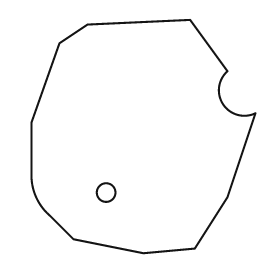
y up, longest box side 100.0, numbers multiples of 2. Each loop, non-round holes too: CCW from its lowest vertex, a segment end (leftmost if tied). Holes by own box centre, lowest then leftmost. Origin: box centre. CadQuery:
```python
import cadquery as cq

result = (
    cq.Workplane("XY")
    .moveTo(0.0, -50.0)
    .lineTo(22.0, -48.0)
    .lineTo(36.0, -26.0)
    .lineTo(48.0, 10.0)
    .threePointArc((34.0, 14.0), (36.0, 28.0))
    .lineTo(20.0, 50.0)
    .lineTo(-24.0, 48.0)
    .lineTo(-36.0, 40.0)
    .lineTo(-48.0, 6.0)
    .lineTo(-48.0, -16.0)
    .threePointArc((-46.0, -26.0), (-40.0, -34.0))
    .lineTo(-30.0, -44.0)
    .close()
    .moveTo(-16.0, -24.0)
    .circle(4.0)
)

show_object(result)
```